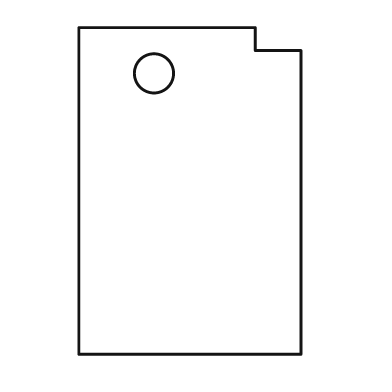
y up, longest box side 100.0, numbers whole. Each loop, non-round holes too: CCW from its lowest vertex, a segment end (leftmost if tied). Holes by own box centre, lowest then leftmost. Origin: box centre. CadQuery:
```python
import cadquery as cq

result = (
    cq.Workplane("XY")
    .moveTo(-34.0, -50.0)
    .lineTo(34.0, -50.0)
    .lineTo(34.0, 43.0)
    .lineTo(20.0, 43.0)
    .lineTo(20.0, 50.0)
    .lineTo(-34.0, 50.0)
    .close()
    .moveTo(-11.0, 36.0)
    .circle(6.0)
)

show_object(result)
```